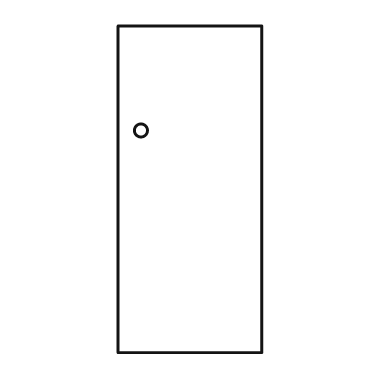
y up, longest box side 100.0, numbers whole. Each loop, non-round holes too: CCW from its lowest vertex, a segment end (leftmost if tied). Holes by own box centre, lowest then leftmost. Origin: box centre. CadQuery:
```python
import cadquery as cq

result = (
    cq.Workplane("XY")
    .moveTo(-22.0, -50.0)
    .lineTo(22.0, -50.0)
    .lineTo(22.0, 50.0)
    .lineTo(-22.0, 50.0)
    .close()
    .moveTo(-15.0, 18.0)
    .circle(2.0)
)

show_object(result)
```